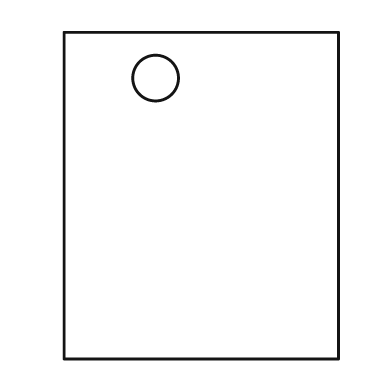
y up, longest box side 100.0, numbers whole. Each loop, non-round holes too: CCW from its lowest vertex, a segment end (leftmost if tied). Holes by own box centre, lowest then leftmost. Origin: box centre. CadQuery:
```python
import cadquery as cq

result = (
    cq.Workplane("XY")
    .moveTo(-42.0, -50.0)
    .lineTo(42.0, -50.0)
    .lineTo(42.0, 50.0)
    .lineTo(-42.0, 50.0)
    .close()
    .moveTo(-14.0, 36.0)
    .circle(7.0)
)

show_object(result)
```